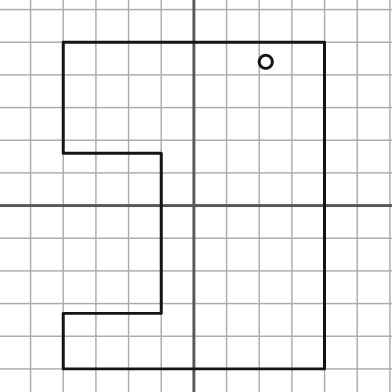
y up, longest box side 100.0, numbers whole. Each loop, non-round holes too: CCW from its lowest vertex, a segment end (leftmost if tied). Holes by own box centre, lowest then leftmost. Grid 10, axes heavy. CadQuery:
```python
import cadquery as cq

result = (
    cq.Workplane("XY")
    .moveTo(-40.0, -50.0)
    .lineTo(40.0, -50.0)
    .lineTo(40.0, 50.0)
    .lineTo(-40.0, 50.0)
    .lineTo(-40.0, 16.0)
    .lineTo(-10.0, 16.0)
    .lineTo(-10.0, -33.0)
    .lineTo(-40.0, -33.0)
    .close()
    .moveTo(22.0, 44.0)
    .circle(2.0)
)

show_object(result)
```